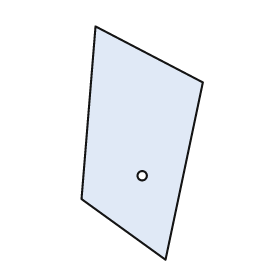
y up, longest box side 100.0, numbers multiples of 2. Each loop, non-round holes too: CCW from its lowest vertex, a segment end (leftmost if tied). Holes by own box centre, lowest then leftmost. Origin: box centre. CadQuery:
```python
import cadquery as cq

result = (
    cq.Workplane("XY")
    .moveTo(10.0, -50.0)
    .lineTo(26.0, 26.0)
    .lineTo(-20.0, 50.0)
    .lineTo(-26.0, -24.0)
    .close()
    .moveTo(0.0, -14.0)
    .circle(2.0)
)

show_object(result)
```